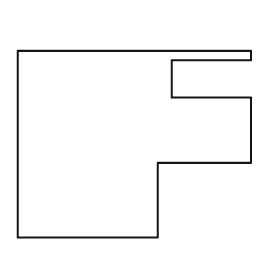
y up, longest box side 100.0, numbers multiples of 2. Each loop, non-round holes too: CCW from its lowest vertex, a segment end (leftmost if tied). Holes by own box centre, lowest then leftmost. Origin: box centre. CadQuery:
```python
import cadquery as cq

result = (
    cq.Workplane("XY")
    .moveTo(-50.0, -40.0)
    .lineTo(10.0, -40.0)
    .lineTo(10.0, -8.0)
    .lineTo(50.0, -8.0)
    .lineTo(50.0, 20.0)
    .lineTo(16.0, 20.0)
    .lineTo(16.0, 36.0)
    .lineTo(50.0, 36.0)
    .lineTo(50.0, 40.0)
    .lineTo(-50.0, 40.0)
    .close()
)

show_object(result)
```